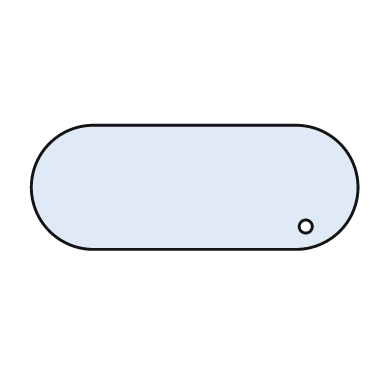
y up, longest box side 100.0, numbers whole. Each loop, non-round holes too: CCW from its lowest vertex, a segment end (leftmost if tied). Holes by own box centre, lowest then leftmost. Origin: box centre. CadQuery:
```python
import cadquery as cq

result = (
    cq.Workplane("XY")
    .moveTo(-31.0, -19.0)
    .lineTo(31.0, -19.0)
    .threePointArc((50.0, 0.0), (31.0, 19.0))
    .lineTo(-31.0, 19.0)
    .threePointArc((-50.0, 0.0), (-31.0, -19.0))
    .close()
    .moveTo(34.0, -12.0)
    .circle(2.0)
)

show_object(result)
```